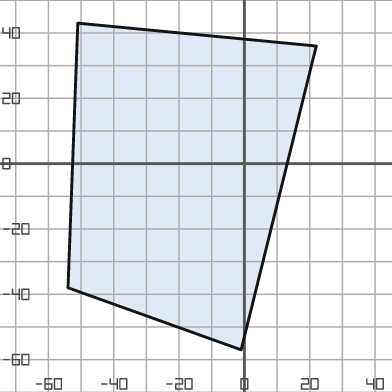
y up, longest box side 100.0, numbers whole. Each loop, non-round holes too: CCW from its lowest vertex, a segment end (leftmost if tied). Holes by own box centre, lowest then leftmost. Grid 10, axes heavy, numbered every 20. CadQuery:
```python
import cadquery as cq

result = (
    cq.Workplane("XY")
    .moveTo(-1.0, -57.0)
    .lineTo(22.0, 36.0)
    .lineTo(-51.0, 43.0)
    .lineTo(-54.0, -38.0)
    .close()
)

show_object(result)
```